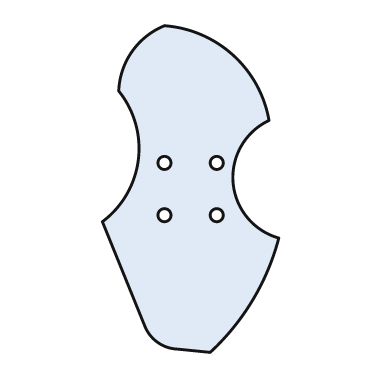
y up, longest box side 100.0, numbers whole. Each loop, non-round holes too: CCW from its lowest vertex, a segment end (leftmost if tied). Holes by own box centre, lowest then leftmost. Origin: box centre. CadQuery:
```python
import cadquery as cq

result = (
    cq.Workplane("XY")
    .moveTo(6.0, -50.0)
    .threePointArc((19.0, -34.0), (27.0, -15.0))
    .threePointArc((13.0, 2.0), (24.0, 21.0))
    .threePointArc((13.0, 41.0), (-8.0, 50.0))
    .threePointArc((-18.0, 42.0), (-22.0, 30.0))
    .threePointArc((-16.0, 9.0), (-27.0, -10.0))
    .lineTo(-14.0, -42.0)
    .threePointArc((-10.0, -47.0), (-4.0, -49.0))
    .close()
    .moveTo(-8.0, -8.0)
    .circle(2.0)
    .moveTo(8.0, -8.0)
    .circle(2.0)
    .moveTo(-8.0, 8.0)
    .circle(2.0)
    .moveTo(8.0, 8.0)
    .circle(2.0)
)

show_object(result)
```